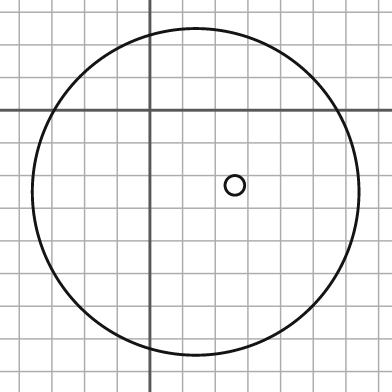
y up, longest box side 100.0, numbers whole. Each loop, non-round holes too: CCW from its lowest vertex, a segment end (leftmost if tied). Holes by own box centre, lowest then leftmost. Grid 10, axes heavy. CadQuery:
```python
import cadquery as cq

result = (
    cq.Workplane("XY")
    .moveTo(14.0, -25.0)
    .circle(50.0)
    .moveTo(26.0, -23.0)
    .circle(3.0)
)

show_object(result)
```